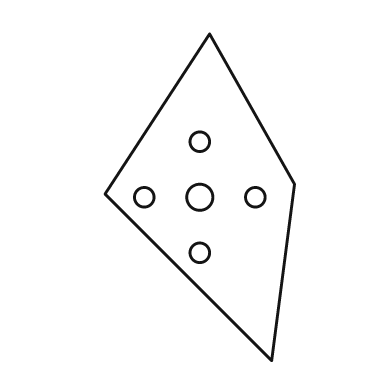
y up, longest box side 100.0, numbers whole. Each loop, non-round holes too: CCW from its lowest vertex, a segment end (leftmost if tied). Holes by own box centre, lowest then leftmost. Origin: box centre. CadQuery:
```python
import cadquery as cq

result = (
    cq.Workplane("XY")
    .moveTo(22.0, -50.0)
    .lineTo(29.0, 4.0)
    .lineTo(3.0, 50.0)
    .lineTo(-29.0, 1.0)
    .close()
    .moveTo(0.0, -17.0)
    .circle(3.0)
    .moveTo(-17.0, 0.0)
    .circle(3.0)
    .moveTo(0.0, 0.0)
    .circle(4.0)
    .moveTo(17.0, 0.0)
    .circle(3.0)
    .moveTo(0.0, 17.0)
    .circle(3.0)
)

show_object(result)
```